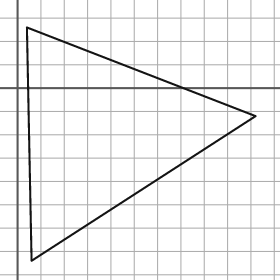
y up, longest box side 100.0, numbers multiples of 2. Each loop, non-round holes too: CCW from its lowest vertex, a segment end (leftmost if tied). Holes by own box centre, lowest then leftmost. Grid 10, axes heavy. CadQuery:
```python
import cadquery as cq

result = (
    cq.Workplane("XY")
    .moveTo(6.0, -74.0)
    .lineTo(102.0, -12.0)
    .lineTo(4.0, 26.0)
    .close()
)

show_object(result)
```